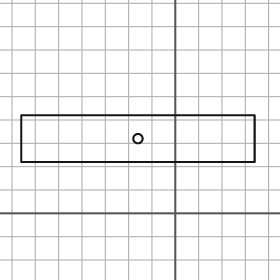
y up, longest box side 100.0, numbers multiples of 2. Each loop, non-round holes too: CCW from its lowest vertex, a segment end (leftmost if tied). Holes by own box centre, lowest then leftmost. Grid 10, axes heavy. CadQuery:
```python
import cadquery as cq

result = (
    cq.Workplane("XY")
    .moveTo(-66.0, 22.0)
    .lineTo(34.0, 22.0)
    .lineTo(34.0, 42.0)
    .lineTo(-66.0, 42.0)
    .close()
    .moveTo(-16.0, 32.0)
    .circle(2.0)
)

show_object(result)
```